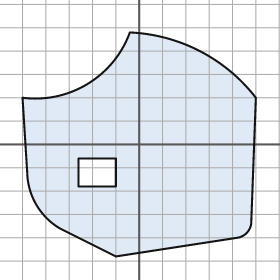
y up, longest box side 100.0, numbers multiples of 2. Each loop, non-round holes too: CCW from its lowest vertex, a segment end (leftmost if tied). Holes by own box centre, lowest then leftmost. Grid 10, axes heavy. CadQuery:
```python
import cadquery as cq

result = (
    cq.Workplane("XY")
    .moveTo(-10.0, -48.0)
    .lineTo(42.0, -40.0)
    .threePointArc((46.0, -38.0), (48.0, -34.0))
    .lineTo(50.0, 20.0)
    .threePointArc((26.0, 40.0), (-4.0, 48.0))
    .threePointArc((-22.0, 26.0), (-50.0, 20.0))
    .lineTo(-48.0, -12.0)
    .threePointArc((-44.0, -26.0), (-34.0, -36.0))
    .close()
    .moveTo(-26.0, -18.0)
    .lineTo(-10.0, -18.0)
    .lineTo(-10.0, -6.0)
    .lineTo(-26.0, -6.0)
    .close()
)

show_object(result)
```